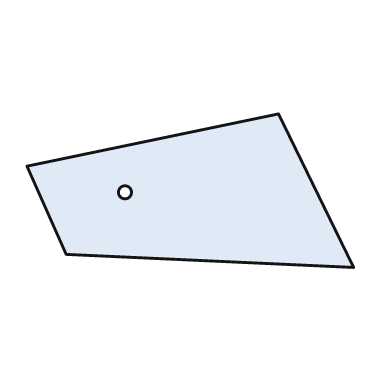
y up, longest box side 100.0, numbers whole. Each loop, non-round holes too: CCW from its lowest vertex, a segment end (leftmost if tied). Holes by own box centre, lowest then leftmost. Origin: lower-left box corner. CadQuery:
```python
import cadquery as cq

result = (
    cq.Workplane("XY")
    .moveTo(100.0, 0.0)
    .lineTo(77.0, 47.0)
    .lineTo(0.0, 31.0)
    .lineTo(12.0, 4.0)
    .close()
    .moveTo(30.0, 23.0)
    .circle(2.0)
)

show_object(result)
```